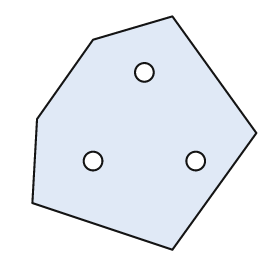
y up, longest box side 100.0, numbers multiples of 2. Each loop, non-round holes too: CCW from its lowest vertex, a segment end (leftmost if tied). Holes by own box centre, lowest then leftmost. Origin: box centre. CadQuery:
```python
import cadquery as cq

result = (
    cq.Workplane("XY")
    .moveTo(12.0, -50.0)
    .lineTo(48.0, 0.0)
    .lineTo(12.0, 50.0)
    .lineTo(-22.0, 40.0)
    .lineTo(-46.0, 6.0)
    .lineTo(-48.0, -30.0)
    .close()
    .moveTo(-22.0, -12.0)
    .circle(4.0)
    .moveTo(22.0, -12.0)
    .circle(4.0)
    .moveTo(0.0, 26.0)
    .circle(4.0)
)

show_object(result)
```